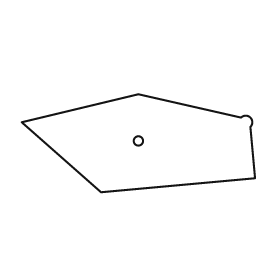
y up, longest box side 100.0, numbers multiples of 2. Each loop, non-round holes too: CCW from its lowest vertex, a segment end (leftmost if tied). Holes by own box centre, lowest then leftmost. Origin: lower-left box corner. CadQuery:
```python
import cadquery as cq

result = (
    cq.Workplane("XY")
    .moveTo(34.0, 0.0)
    .lineTo(100.0, 6.0)
    .lineTo(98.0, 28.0)
    .threePointArc((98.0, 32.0), (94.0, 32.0))
    .lineTo(50.0, 42.0)
    .lineTo(0.0, 30.0)
    .close()
    .moveTo(50.0, 22.0)
    .circle(2.0)
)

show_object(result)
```